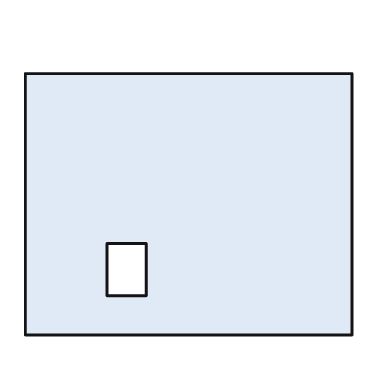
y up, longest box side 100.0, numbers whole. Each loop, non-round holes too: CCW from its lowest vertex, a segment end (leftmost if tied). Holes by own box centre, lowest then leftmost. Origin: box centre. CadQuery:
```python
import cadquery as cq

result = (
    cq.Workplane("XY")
    .moveTo(-50.0, -40.0)
    .lineTo(50.0, -40.0)
    .lineTo(50.0, 40.0)
    .lineTo(-50.0, 40.0)
    .close()
    .moveTo(-25.0, -28.0)
    .lineTo(-13.0, -28.0)
    .lineTo(-13.0, -12.0)
    .lineTo(-25.0, -12.0)
    .close()
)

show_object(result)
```